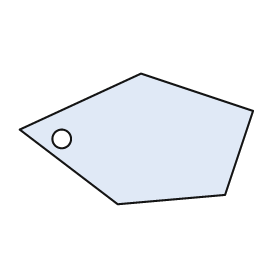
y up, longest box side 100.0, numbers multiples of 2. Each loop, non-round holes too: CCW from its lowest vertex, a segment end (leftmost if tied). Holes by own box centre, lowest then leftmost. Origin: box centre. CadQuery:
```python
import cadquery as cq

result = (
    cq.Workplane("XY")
    .moveTo(-8.0, -28.0)
    .lineTo(38.0, -24.0)
    .lineTo(50.0, 12.0)
    .lineTo(2.0, 28.0)
    .lineTo(-50.0, 4.0)
    .close()
    .moveTo(-32.0, 0.0)
    .circle(4.0)
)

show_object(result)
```